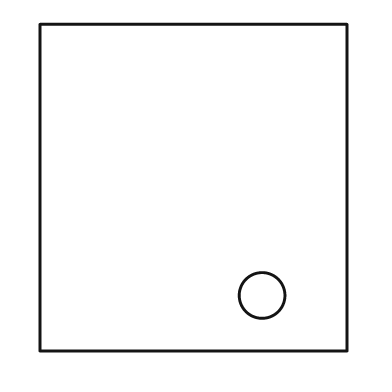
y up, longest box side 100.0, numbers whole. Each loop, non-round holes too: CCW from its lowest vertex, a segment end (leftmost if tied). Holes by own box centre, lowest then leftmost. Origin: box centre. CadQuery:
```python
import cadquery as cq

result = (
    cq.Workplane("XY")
    .moveTo(-47.0, -50.0)
    .lineTo(47.0, -50.0)
    .lineTo(47.0, 50.0)
    .lineTo(-47.0, 50.0)
    .close()
    .moveTo(21.0, -33.0)
    .circle(7.0)
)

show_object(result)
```